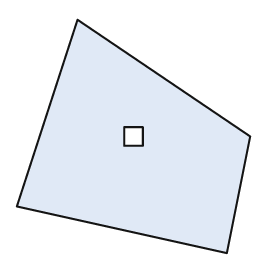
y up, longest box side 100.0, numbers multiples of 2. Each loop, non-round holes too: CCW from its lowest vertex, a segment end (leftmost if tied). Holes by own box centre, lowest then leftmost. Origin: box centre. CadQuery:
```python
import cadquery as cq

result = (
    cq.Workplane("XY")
    .moveTo(40.0, -50.0)
    .lineTo(50.0, 0.0)
    .lineTo(-24.0, 50.0)
    .lineTo(-50.0, -30.0)
    .close()
    .moveTo(-4.0, -4.0)
    .lineTo(4.0, -4.0)
    .lineTo(4.0, 4.0)
    .lineTo(-4.0, 4.0)
    .close()
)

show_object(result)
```